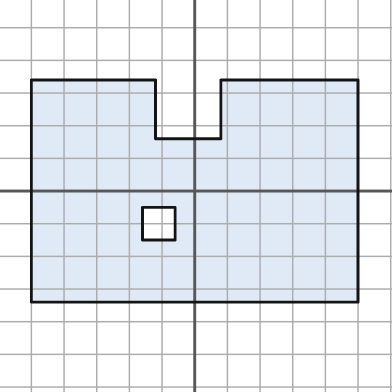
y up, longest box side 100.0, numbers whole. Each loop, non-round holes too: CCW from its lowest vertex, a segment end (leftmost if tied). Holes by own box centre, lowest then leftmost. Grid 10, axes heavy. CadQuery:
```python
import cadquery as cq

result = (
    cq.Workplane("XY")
    .moveTo(-50.0, -34.0)
    .lineTo(50.0, -34.0)
    .lineTo(50.0, 34.0)
    .lineTo(8.0, 34.0)
    .lineTo(8.0, 16.0)
    .lineTo(-12.0, 16.0)
    .lineTo(-12.0, 34.0)
    .lineTo(-50.0, 34.0)
    .close()
    .moveTo(-16.0, -15.0)
    .lineTo(-6.0, -15.0)
    .lineTo(-6.0, -5.0)
    .lineTo(-16.0, -5.0)
    .close()
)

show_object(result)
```